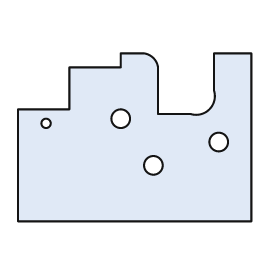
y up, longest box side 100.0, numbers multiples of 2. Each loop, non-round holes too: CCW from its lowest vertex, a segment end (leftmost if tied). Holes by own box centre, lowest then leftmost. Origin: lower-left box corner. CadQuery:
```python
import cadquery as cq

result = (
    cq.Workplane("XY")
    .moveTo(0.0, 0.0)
    .lineTo(100.0, 0.0)
    .lineTo(100.0, 72.0)
    .lineTo(84.0, 72.0)
    .lineTo(84.0, 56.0)
    .threePointArc((82.0, 48.0), (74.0, 46.0))
    .lineTo(60.0, 46.0)
    .lineTo(60.0, 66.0)
    .threePointArc((58.0, 70.0), (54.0, 72.0))
    .lineTo(44.0, 72.0)
    .lineTo(44.0, 66.0)
    .lineTo(22.0, 66.0)
    .lineTo(22.0, 48.0)
    .lineTo(0.0, 48.0)
    .close()
    .moveTo(58.0, 24.0)
    .circle(4.0)
    .moveTo(86.0, 34.0)
    .circle(4.0)
    .moveTo(12.0, 42.0)
    .circle(2.0)
    .moveTo(44.0, 44.0)
    .circle(4.0)
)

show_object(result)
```